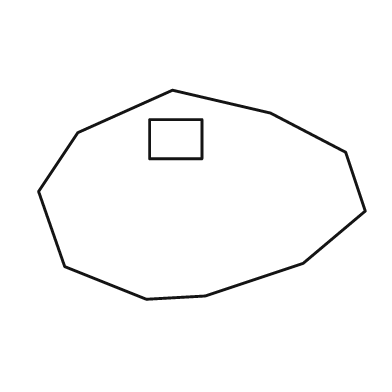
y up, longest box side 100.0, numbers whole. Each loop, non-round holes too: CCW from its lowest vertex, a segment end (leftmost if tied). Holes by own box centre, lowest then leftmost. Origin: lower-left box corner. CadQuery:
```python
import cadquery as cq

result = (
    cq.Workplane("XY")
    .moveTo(33.0, 0.0)
    .lineTo(51.0, 1.0)
    .lineTo(81.0, 11.0)
    .lineTo(100.0, 27.0)
    .lineTo(94.0, 45.0)
    .lineTo(71.0, 57.0)
    .lineTo(41.0, 64.0)
    .lineTo(12.0, 51.0)
    .lineTo(0.0, 33.0)
    .lineTo(8.0, 10.0)
    .close()
    .moveTo(34.0, 43.0)
    .lineTo(50.0, 43.0)
    .lineTo(50.0, 55.0)
    .lineTo(34.0, 55.0)
    .close()
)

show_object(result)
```